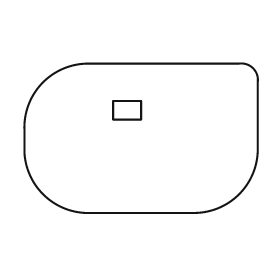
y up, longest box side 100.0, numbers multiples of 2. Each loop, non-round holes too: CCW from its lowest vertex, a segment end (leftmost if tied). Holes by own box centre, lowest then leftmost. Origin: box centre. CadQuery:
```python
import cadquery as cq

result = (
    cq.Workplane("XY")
    .moveTo(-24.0, -32.0)
    .lineTo(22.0, -32.0)
    .threePointArc((42.0, -24.0), (50.0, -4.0))
    .lineTo(50.0, 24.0)
    .threePointArc((48.0, 30.0), (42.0, 32.0))
    .lineTo(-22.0, 32.0)
    .threePointArc((-42.0, 24.0), (-50.0, 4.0))
    .lineTo(-50.0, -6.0)
    .threePointArc((-42.0, -24.0), (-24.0, -32.0))
    .close()
    .moveTo(-12.0, 8.0)
    .lineTo(0.0, 8.0)
    .lineTo(0.0, 16.0)
    .lineTo(-12.0, 16.0)
    .close()
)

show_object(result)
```